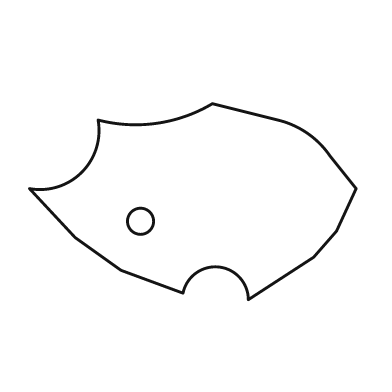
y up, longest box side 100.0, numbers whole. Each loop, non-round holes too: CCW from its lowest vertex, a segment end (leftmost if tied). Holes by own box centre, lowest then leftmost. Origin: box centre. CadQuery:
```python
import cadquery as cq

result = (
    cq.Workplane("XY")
    .moveTo(17.0, -30.0)
    .lineTo(37.0, -17.0)
    .lineTo(44.0, -9.0)
    .lineTo(50.0, 4.0)
    .lineTo(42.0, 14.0)
    .threePointArc((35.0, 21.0), (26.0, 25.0))
    .lineTo(6.0, 30.0)
    .threePointArc((-11.0, 24.0), (-29.0, 25.0))
    .threePointArc((-34.0, 9.0), (-50.0, 4.0))
    .lineTo(-36.0, -11.0)
    .lineTo(-22.0, -21.0)
    .lineTo(-3.0, -28.0)
    .threePointArc((8.0, -20.0), (17.0, -30.0))
    .close()
    .moveTo(-16.0, -6.0)
    .circle(4.0)
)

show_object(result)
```